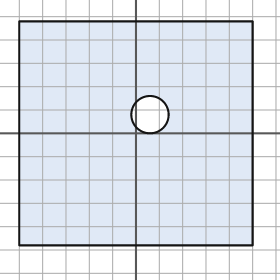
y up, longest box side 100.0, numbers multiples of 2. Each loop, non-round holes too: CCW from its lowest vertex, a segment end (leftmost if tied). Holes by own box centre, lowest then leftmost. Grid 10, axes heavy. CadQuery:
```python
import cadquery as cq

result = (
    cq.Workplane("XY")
    .moveTo(-50.0, -48.0)
    .lineTo(50.0, -48.0)
    .lineTo(50.0, 48.0)
    .lineTo(-50.0, 48.0)
    .close()
    .moveTo(6.0, 8.0)
    .circle(8.0)
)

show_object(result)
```